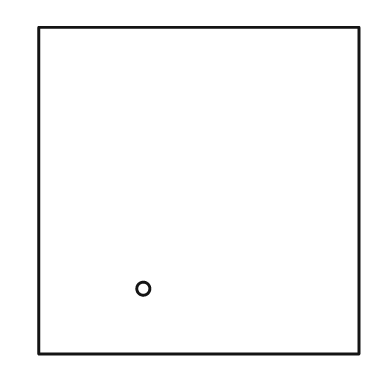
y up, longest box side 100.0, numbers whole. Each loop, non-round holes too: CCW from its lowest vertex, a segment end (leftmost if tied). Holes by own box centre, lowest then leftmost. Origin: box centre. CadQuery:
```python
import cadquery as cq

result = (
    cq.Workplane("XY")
    .moveTo(-49.0, -50.0)
    .lineTo(49.0, -50.0)
    .lineTo(49.0, 50.0)
    .lineTo(-49.0, 50.0)
    .close()
    .moveTo(-17.0, -30.0)
    .circle(2.0)
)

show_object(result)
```